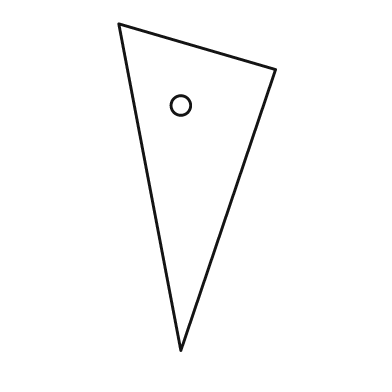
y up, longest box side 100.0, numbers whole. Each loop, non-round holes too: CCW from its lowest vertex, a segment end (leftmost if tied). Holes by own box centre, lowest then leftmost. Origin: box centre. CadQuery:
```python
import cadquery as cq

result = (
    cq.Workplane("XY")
    .moveTo(-5.0, -50.0)
    .lineTo(24.0, 36.0)
    .lineTo(-24.0, 50.0)
    .close()
    .moveTo(-5.0, 25.0)
    .circle(3.0)
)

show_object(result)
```